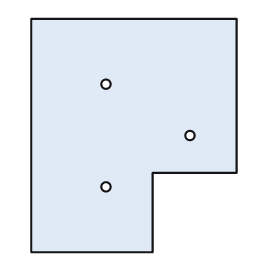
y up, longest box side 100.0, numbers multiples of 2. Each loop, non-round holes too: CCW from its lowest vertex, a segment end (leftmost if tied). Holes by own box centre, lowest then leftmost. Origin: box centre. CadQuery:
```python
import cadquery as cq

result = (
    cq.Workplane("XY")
    .moveTo(-44.0, -50.0)
    .lineTo(8.0, -50.0)
    .lineTo(8.0, -16.0)
    .lineTo(44.0, -16.0)
    .lineTo(44.0, 50.0)
    .lineTo(-44.0, 50.0)
    .close()
    .moveTo(-12.0, -22.0)
    .circle(2.0)
    .moveTo(24.0, 0.0)
    .circle(2.0)
    .moveTo(-12.0, 22.0)
    .circle(2.0)
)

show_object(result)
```